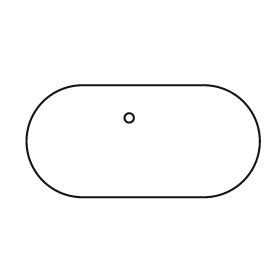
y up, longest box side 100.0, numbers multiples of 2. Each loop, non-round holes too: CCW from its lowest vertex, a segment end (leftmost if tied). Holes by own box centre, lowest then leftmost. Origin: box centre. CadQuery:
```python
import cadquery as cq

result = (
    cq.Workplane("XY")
    .moveTo(-26.0, -24.0)
    .lineTo(26.0, -24.0)
    .threePointArc((50.0, 0.0), (26.0, 24.0))
    .lineTo(-26.0, 24.0)
    .threePointArc((-50.0, 0.0), (-26.0, -24.0))
    .close()
    .moveTo(-6.0, 10.0)
    .circle(2.0)
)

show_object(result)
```